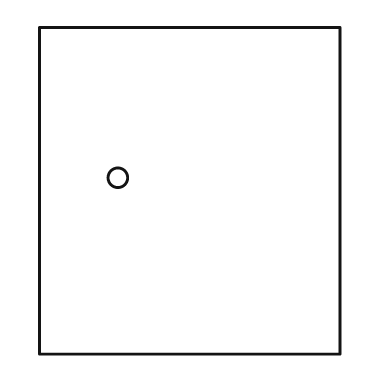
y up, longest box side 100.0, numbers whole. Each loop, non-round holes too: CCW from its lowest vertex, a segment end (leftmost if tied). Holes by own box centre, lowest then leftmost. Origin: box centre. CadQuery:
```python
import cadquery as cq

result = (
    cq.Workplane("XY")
    .moveTo(-46.0, -50.0)
    .lineTo(46.0, -50.0)
    .lineTo(46.0, 50.0)
    .lineTo(-46.0, 50.0)
    .close()
    .moveTo(-22.0, 4.0)
    .circle(3.0)
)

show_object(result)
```